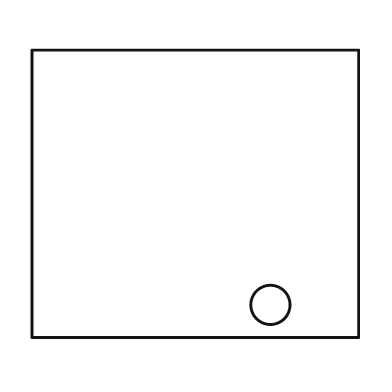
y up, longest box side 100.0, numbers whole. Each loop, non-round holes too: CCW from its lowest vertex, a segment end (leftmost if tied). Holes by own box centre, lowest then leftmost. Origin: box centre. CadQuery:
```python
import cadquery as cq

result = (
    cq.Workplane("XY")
    .moveTo(-50.0, -44.0)
    .lineTo(50.0, -44.0)
    .lineTo(50.0, 44.0)
    .lineTo(-50.0, 44.0)
    .close()
    .moveTo(23.0, -34.0)
    .circle(6.0)
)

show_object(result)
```